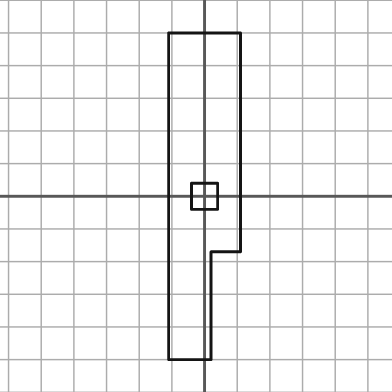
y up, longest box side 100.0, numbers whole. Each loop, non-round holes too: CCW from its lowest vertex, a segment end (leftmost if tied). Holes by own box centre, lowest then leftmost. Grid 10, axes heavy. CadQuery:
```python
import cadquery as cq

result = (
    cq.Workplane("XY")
    .moveTo(-11.0, -50.0)
    .lineTo(2.0, -50.0)
    .lineTo(2.0, -17.0)
    .lineTo(11.0, -17.0)
    .lineTo(11.0, 50.0)
    .lineTo(-11.0, 50.0)
    .close()
    .moveTo(-4.0, -4.0)
    .lineTo(4.0, -4.0)
    .lineTo(4.0, 4.0)
    .lineTo(-4.0, 4.0)
    .close()
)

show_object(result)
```